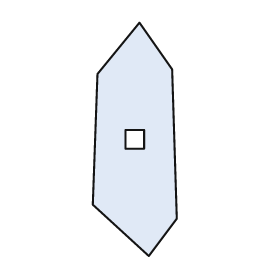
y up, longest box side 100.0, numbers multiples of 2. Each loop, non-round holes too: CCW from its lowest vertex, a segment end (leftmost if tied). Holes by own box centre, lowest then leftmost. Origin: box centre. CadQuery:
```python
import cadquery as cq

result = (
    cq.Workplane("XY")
    .moveTo(6.0, -50.0)
    .lineTo(18.0, -34.0)
    .lineTo(16.0, 30.0)
    .lineTo(2.0, 50.0)
    .lineTo(-16.0, 28.0)
    .lineTo(-18.0, -28.0)
    .close()
    .moveTo(-4.0, -4.0)
    .lineTo(4.0, -4.0)
    .lineTo(4.0, 4.0)
    .lineTo(-4.0, 4.0)
    .close()
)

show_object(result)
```